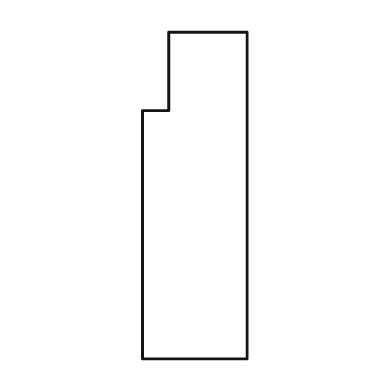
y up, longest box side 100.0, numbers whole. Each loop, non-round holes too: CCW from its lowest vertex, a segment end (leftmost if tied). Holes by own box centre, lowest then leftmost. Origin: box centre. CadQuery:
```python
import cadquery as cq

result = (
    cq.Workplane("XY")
    .moveTo(-16.0, -50.0)
    .lineTo(16.0, -50.0)
    .lineTo(16.0, 50.0)
    .lineTo(-8.0, 50.0)
    .lineTo(-8.0, 26.0)
    .lineTo(-16.0, 26.0)
    .close()
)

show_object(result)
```